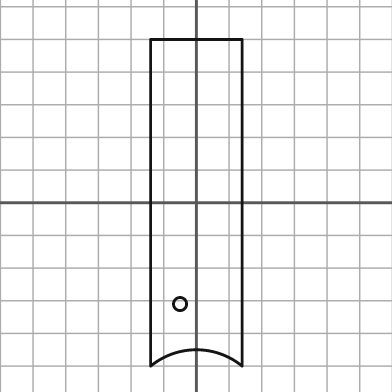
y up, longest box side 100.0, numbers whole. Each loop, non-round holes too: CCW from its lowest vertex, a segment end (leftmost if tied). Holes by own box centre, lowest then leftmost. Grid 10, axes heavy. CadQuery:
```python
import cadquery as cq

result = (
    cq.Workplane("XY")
    .moveTo(-14.0, -50.0)
    .threePointArc((0.0, -45.0), (14.0, -50.0))
    .lineTo(14.0, 50.0)
    .lineTo(-14.0, 50.0)
    .close()
    .moveTo(-5.0, -31.0)
    .circle(2.0)
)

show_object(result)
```